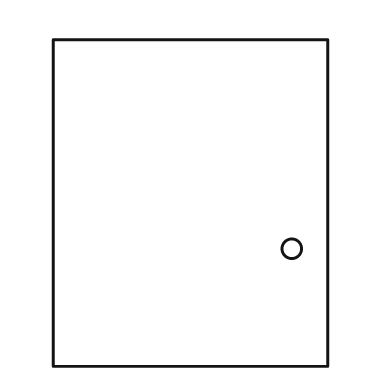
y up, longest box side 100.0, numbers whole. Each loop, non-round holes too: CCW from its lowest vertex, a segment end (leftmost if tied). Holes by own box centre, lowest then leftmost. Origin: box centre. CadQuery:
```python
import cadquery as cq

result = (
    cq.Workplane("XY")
    .moveTo(-42.0, -50.0)
    .lineTo(42.0, -50.0)
    .lineTo(42.0, 50.0)
    .lineTo(-42.0, 50.0)
    .close()
    .moveTo(31.0, -14.0)
    .circle(3.0)
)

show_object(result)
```